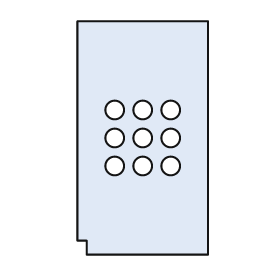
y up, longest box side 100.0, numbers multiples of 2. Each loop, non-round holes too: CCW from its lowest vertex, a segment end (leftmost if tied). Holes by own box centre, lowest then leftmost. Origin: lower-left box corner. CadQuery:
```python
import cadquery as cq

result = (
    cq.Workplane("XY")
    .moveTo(4.0, 0.0)
    .lineTo(56.0, 0.0)
    .lineTo(56.0, 100.0)
    .lineTo(0.0, 100.0)
    .lineTo(0.0, 6.0)
    .lineTo(4.0, 6.0)
    .close()
    .moveTo(16.0, 38.0)
    .circle(4.0)
    .moveTo(28.0, 38.0)
    .circle(4.0)
    .moveTo(40.0, 38.0)
    .circle(4.0)
    .moveTo(16.0, 50.0)
    .circle(4.0)
    .moveTo(28.0, 50.0)
    .circle(4.0)
    .moveTo(40.0, 50.0)
    .circle(4.0)
    .moveTo(16.0, 62.0)
    .circle(4.0)
    .moveTo(28.0, 62.0)
    .circle(4.0)
    .moveTo(40.0, 62.0)
    .circle(4.0)
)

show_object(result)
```